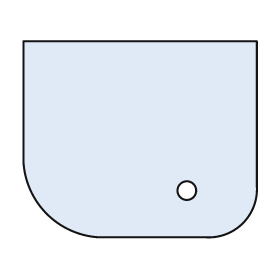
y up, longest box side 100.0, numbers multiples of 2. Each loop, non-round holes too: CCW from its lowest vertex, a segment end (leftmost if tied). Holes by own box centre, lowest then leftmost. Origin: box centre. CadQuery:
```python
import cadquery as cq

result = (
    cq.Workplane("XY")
    .moveTo(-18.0, -42.0)
    .lineTo(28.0, -42.0)
    .threePointArc((44.0, -36.0), (50.0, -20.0))
    .lineTo(50.0, 42.0)
    .lineTo(-50.0, 42.0)
    .lineTo(-50.0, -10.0)
    .threePointArc((-40.0, -32.0), (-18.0, -42.0))
    .close()
    .moveTo(20.0, -22.0)
    .circle(4.0)
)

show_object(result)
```